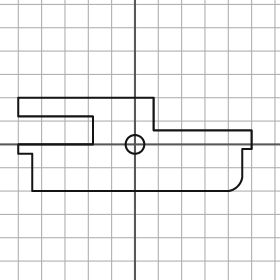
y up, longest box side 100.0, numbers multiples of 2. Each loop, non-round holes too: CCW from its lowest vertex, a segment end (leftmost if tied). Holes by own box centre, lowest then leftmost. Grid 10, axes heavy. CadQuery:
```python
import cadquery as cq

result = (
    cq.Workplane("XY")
    .moveTo(-44.0, -20.0)
    .lineTo(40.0, -20.0)
    .threePointArc((44.0, -18.0), (46.0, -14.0))
    .lineTo(46.0, -2.0)
    .lineTo(50.0, -2.0)
    .lineTo(50.0, 6.0)
    .lineTo(8.0, 6.0)
    .lineTo(8.0, 20.0)
    .lineTo(-50.0, 20.0)
    .lineTo(-50.0, 12.0)
    .lineTo(-18.0, 12.0)
    .lineTo(-18.0, 0.0)
    .lineTo(-50.0, 0.0)
    .lineTo(-50.0, -4.0)
    .lineTo(-44.0, -4.0)
    .close()
    .moveTo(0.0, 0.0)
    .circle(4.0)
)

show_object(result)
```